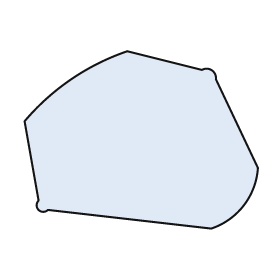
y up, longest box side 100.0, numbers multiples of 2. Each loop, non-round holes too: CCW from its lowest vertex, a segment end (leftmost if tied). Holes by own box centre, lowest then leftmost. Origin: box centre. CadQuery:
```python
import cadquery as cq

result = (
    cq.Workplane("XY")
    .moveTo(30.0, -38.0)
    .threePointArc((44.0, -28.0), (50.0, -12.0))
    .lineTo(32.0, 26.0)
    .threePointArc((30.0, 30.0), (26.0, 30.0))
    .lineTo(-6.0, 38.0)
    .threePointArc((-30.0, 26.0), (-50.0, 8.0))
    .lineTo(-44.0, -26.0)
    .threePointArc((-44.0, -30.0), (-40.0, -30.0))
    .close()
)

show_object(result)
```